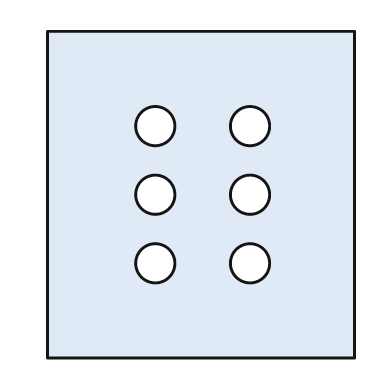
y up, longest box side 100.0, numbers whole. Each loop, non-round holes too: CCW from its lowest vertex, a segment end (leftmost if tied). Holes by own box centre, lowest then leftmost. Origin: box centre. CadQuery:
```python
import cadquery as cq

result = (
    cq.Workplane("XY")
    .moveTo(-47.0, -50.0)
    .lineTo(47.0, -50.0)
    .lineTo(47.0, 50.0)
    .lineTo(-47.0, 50.0)
    .close()
    .moveTo(-14.0, -21.0)
    .circle(6.0)
    .moveTo(15.0, -21.0)
    .circle(6.0)
    .moveTo(-14.0, 0.0)
    .circle(6.0)
    .moveTo(15.0, 0.0)
    .circle(6.0)
    .moveTo(-14.0, 21.0)
    .circle(6.0)
    .moveTo(15.0, 21.0)
    .circle(6.0)
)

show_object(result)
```